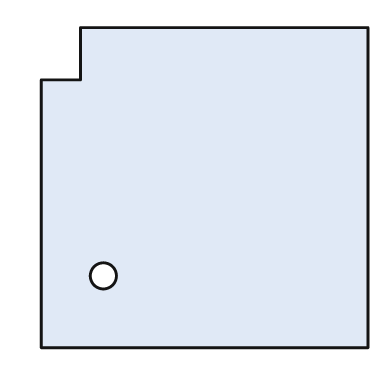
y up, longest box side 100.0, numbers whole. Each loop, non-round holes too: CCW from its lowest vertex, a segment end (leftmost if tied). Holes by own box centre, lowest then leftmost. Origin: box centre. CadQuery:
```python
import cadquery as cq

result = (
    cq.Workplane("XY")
    .moveTo(-50.0, -49.0)
    .lineTo(50.0, -49.0)
    .lineTo(50.0, 49.0)
    .lineTo(-38.0, 49.0)
    .lineTo(-38.0, 33.0)
    .lineTo(-50.0, 33.0)
    .close()
    .moveTo(-31.0, -27.0)
    .circle(4.0)
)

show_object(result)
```